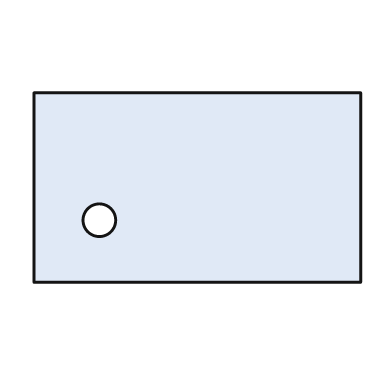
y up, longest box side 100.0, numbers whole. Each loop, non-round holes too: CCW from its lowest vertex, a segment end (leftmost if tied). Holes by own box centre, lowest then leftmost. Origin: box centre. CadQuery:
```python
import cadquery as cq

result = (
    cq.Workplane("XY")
    .moveTo(-50.0, -29.0)
    .lineTo(50.0, -29.0)
    .lineTo(50.0, 29.0)
    .lineTo(-50.0, 29.0)
    .close()
    .moveTo(-30.0, -10.0)
    .circle(5.0)
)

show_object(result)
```